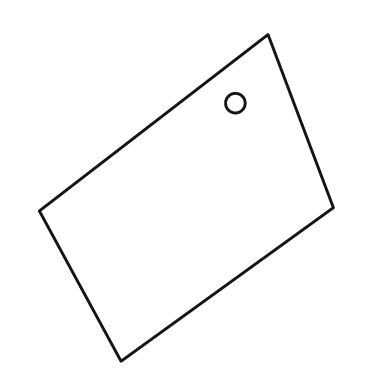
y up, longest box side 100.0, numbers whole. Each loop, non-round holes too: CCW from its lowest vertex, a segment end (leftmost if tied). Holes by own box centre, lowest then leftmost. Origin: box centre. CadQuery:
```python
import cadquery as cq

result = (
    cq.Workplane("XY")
    .moveTo(-20.0, -50.0)
    .lineTo(45.0, -3.0)
    .lineTo(25.0, 50.0)
    .lineTo(-45.0, -4.0)
    .close()
    .moveTo(15.0, 29.0)
    .circle(3.0)
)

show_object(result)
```